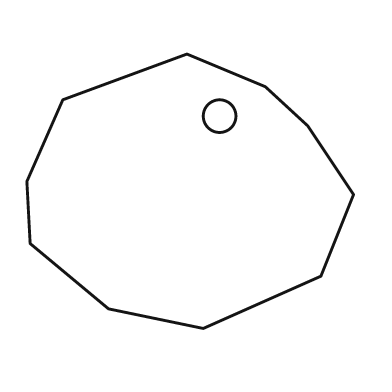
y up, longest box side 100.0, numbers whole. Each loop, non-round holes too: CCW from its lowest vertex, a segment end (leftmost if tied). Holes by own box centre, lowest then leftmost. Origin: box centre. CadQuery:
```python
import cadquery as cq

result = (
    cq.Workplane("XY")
    .moveTo(4.0, -42.0)
    .lineTo(40.0, -26.0)
    .lineTo(50.0, -1.0)
    .lineTo(36.0, 20.0)
    .lineTo(23.0, 32.0)
    .lineTo(-1.0, 42.0)
    .lineTo(-39.0, 28.0)
    .lineTo(-50.0, 3.0)
    .lineTo(-49.0, -16.0)
    .lineTo(-25.0, -36.0)
    .close()
    .moveTo(9.0, 23.0)
    .circle(5.0)
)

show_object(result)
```